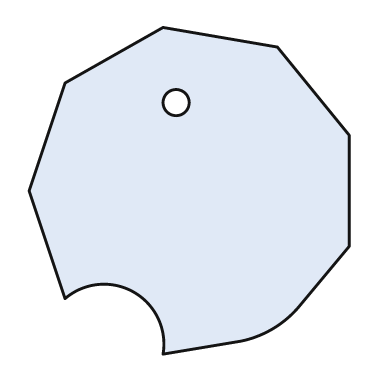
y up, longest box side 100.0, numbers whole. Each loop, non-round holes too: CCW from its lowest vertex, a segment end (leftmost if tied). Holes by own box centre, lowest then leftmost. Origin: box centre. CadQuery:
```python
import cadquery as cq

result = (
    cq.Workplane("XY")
    .moveTo(-8.0, -50.0)
    .lineTo(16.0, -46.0)
    .threePointArc((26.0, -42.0), (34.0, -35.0))
    .lineTo(49.0, -17.0)
    .lineTo(49.0, 17.0)
    .lineTo(27.0, 44.0)
    .lineTo(-8.0, 50.0)
    .lineTo(-38.0, 33.0)
    .lineTo(-49.0, 0.0)
    .lineTo(-38.0, -33.0)
    .threePointArc((-17.0, -31.0), (-8.0, -50.0))
    .close()
    .moveTo(-4.0, 27.0)
    .circle(4.0)
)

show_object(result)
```